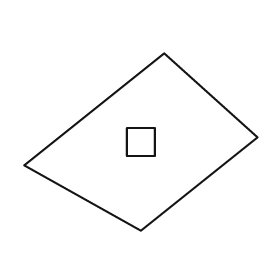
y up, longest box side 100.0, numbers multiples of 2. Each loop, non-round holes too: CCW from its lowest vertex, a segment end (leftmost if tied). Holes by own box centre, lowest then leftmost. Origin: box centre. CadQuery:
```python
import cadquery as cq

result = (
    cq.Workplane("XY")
    .moveTo(0.0, -38.0)
    .lineTo(50.0, 2.0)
    .lineTo(10.0, 38.0)
    .lineTo(-50.0, -10.0)
    .close()
    .moveTo(-6.0, -6.0)
    .lineTo(6.0, -6.0)
    .lineTo(6.0, 6.0)
    .lineTo(-6.0, 6.0)
    .close()
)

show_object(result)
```